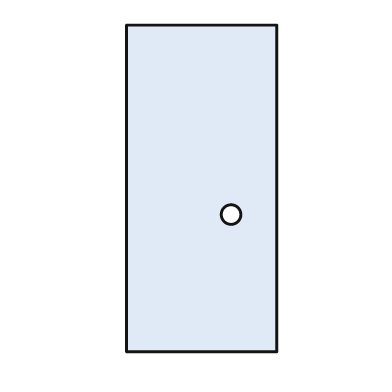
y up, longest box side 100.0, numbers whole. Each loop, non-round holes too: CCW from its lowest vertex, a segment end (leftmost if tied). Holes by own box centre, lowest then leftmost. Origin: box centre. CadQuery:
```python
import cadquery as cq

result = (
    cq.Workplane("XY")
    .moveTo(-23.0, -50.0)
    .lineTo(23.0, -50.0)
    .lineTo(23.0, 50.0)
    .lineTo(-23.0, 50.0)
    .close()
    .moveTo(9.0, -8.0)
    .circle(3.0)
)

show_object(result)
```